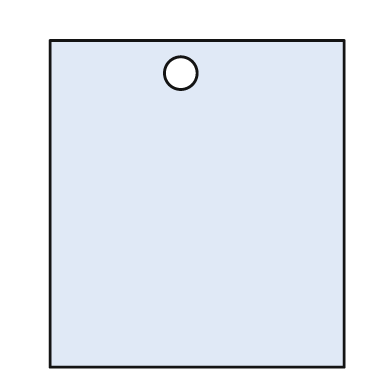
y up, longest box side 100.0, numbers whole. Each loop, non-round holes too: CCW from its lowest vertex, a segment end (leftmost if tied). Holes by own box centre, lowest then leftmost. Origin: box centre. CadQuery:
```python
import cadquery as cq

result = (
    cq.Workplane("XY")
    .moveTo(-45.0, -50.0)
    .lineTo(45.0, -50.0)
    .lineTo(45.0, 50.0)
    .lineTo(-45.0, 50.0)
    .close()
    .moveTo(-5.0, 40.0)
    .circle(5.0)
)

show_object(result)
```